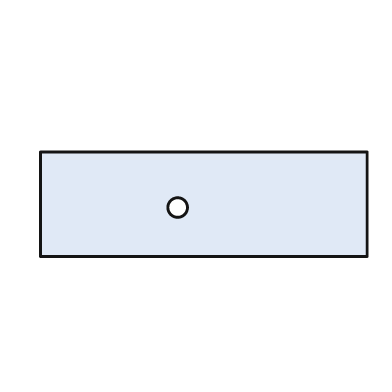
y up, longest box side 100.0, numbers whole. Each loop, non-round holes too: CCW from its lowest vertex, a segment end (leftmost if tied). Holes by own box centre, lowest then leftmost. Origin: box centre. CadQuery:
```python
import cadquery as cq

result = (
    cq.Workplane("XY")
    .moveTo(-50.0, -16.0)
    .lineTo(50.0, -16.0)
    .lineTo(50.0, 16.0)
    .lineTo(-50.0, 16.0)
    .close()
    .moveTo(-8.0, -1.0)
    .circle(3.0)
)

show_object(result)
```